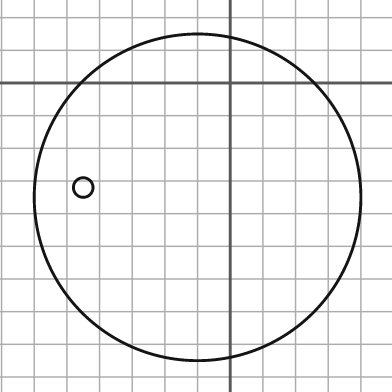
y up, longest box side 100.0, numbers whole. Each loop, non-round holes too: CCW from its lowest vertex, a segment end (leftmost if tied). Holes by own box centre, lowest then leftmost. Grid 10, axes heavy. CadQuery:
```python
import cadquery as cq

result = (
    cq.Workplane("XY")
    .moveTo(-10.0, -35.0)
    .circle(50.0)
    .moveTo(-45.0, -32.0)
    .circle(3.0)
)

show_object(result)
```